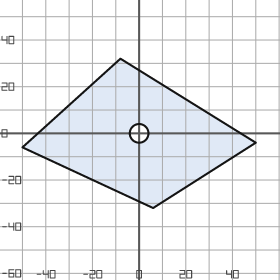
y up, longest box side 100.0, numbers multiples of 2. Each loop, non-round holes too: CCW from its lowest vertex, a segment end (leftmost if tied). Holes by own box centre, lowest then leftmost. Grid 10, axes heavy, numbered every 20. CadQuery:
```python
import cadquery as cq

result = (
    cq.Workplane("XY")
    .moveTo(6.0, -32.0)
    .lineTo(50.0, -4.0)
    .lineTo(-8.0, 32.0)
    .lineTo(-50.0, -6.0)
    .close()
    .moveTo(0.0, 0.0)
    .circle(4.0)
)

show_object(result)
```